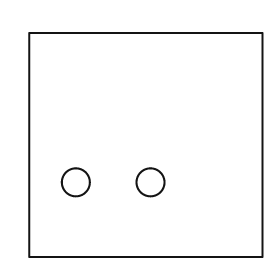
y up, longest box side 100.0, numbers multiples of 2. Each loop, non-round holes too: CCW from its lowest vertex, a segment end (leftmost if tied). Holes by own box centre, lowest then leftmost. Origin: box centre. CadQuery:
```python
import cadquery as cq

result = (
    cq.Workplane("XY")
    .moveTo(-50.0, -48.0)
    .lineTo(50.0, -48.0)
    .lineTo(50.0, 48.0)
    .lineTo(-50.0, 48.0)
    .close()
    .moveTo(-30.0, -16.0)
    .circle(6.0)
    .moveTo(2.0, -16.0)
    .circle(6.0)
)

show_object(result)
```